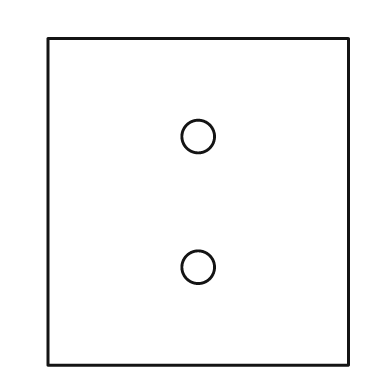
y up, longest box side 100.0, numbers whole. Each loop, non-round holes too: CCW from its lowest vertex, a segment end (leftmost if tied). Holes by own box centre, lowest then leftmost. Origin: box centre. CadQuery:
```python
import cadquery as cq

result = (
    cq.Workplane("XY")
    .moveTo(-46.0, -50.0)
    .lineTo(46.0, -50.0)
    .lineTo(46.0, 50.0)
    .lineTo(-46.0, 50.0)
    .close()
    .moveTo(0.0, -20.0)
    .circle(5.0)
    .moveTo(0.0, 20.0)
    .circle(5.0)
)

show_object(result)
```